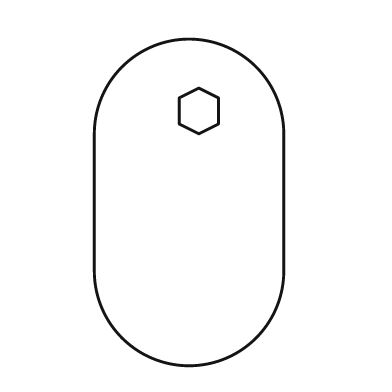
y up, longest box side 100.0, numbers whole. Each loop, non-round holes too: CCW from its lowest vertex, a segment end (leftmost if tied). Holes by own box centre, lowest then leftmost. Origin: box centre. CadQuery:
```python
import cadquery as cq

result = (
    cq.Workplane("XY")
    .moveTo(-29.0, -21.0)
    .threePointArc((0.0, -50.0), (29.0, -21.0))
    .lineTo(29.0, 21.0)
    .threePointArc((0.0, 50.0), (-29.0, 21.0))
    .close()
    .moveTo(3.0, 21.0)
    .lineTo(9.0, 24.0)
    .lineTo(9.0, 32.0)
    .lineTo(3.0, 35.0)
    .lineTo(-3.0, 32.0)
    .lineTo(-3.0, 24.0)
    .close()
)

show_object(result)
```